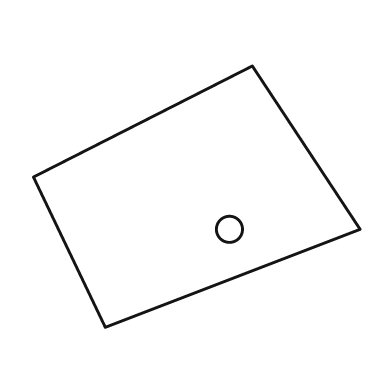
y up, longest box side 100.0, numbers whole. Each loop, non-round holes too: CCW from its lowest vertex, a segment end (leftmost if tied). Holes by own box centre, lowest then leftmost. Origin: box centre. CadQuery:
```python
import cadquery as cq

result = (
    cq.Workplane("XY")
    .moveTo(-28.0, -40.0)
    .lineTo(50.0, -10.0)
    .lineTo(17.0, 40.0)
    .lineTo(-50.0, 6.0)
    .close()
    .moveTo(10.0, -10.0)
    .circle(4.0)
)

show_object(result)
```